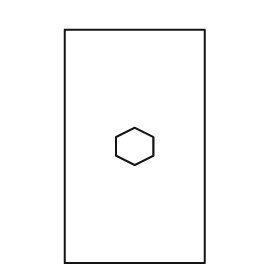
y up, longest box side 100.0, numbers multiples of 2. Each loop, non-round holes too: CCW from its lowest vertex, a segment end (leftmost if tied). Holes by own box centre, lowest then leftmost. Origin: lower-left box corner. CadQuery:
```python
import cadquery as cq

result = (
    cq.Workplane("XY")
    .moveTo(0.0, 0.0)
    .lineTo(60.0, 0.0)
    .lineTo(60.0, 100.0)
    .lineTo(0.0, 100.0)
    .close()
    .moveTo(30.0, 42.0)
    .lineTo(38.0, 46.0)
    .lineTo(38.0, 54.0)
    .lineTo(30.0, 58.0)
    .lineTo(22.0, 54.0)
    .lineTo(22.0, 46.0)
    .close()
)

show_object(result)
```